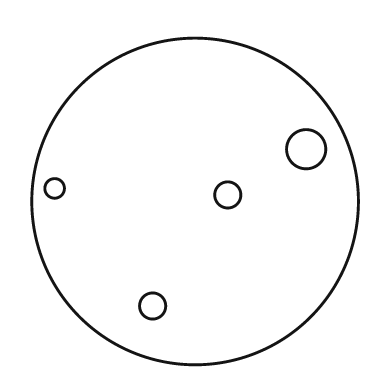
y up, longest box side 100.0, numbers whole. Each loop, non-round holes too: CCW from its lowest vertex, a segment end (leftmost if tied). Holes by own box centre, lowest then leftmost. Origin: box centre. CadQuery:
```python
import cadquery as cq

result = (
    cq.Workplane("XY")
    .moveTo(0.0, 0.0)
    .circle(50.0)
    .moveTo(-13.0, -32.0)
    .circle(4.0)
    .moveTo(10.0, 2.0)
    .circle(4.0)
    .moveTo(-43.0, 4.0)
    .circle(3.0)
    .moveTo(34.0, 16.0)
    .circle(6.0)
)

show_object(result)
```